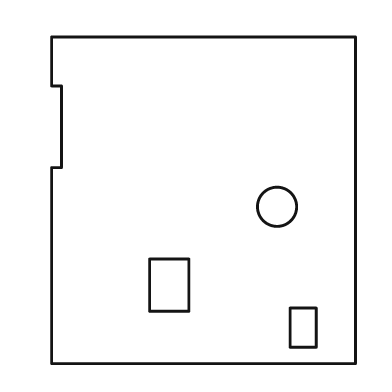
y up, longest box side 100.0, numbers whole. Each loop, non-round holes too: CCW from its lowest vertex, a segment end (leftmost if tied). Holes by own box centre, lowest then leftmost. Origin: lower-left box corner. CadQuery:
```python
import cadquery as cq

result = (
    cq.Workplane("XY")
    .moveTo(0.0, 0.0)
    .lineTo(93.0, 0.0)
    .lineTo(93.0, 100.0)
    .lineTo(0.0, 100.0)
    .lineTo(0.0, 85.0)
    .lineTo(3.0, 85.0)
    .lineTo(3.0, 60.0)
    .lineTo(0.0, 60.0)
    .close()
    .moveTo(73.0, 5.0)
    .lineTo(81.0, 5.0)
    .lineTo(81.0, 17.0)
    .lineTo(73.0, 17.0)
    .close()
    .moveTo(30.0, 16.0)
    .lineTo(42.0, 16.0)
    .lineTo(42.0, 32.0)
    .lineTo(30.0, 32.0)
    .close()
    .moveTo(69.0, 48.0)
    .circle(6.0)
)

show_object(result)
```